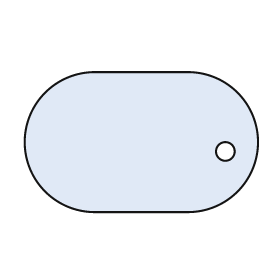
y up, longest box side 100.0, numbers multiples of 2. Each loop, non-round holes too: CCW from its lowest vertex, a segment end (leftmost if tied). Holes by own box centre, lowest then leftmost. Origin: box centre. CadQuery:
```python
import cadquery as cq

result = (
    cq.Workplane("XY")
    .moveTo(-20.0, -30.0)
    .lineTo(20.0, -30.0)
    .threePointArc((50.0, 0.0), (20.0, 30.0))
    .lineTo(-20.0, 30.0)
    .threePointArc((-50.0, 0.0), (-20.0, -30.0))
    .close()
    .moveTo(36.0, -4.0)
    .circle(4.0)
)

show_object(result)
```